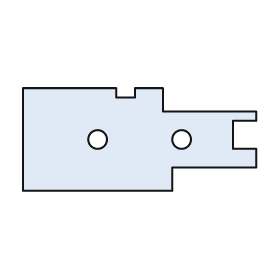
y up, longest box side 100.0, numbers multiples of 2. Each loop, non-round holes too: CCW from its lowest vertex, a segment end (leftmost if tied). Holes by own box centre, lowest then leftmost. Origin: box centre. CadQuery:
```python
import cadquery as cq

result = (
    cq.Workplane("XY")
    .moveTo(-50.0, -22.0)
    .lineTo(14.0, -22.0)
    .lineTo(14.0, -12.0)
    .lineTo(50.0, -12.0)
    .lineTo(50.0, -4.0)
    .lineTo(40.0, -4.0)
    .lineTo(40.0, 8.0)
    .lineTo(50.0, 8.0)
    .lineTo(50.0, 12.0)
    .lineTo(10.0, 12.0)
    .lineTo(10.0, 22.0)
    .lineTo(-2.0, 22.0)
    .lineTo(-2.0, 18.0)
    .lineTo(-10.0, 18.0)
    .lineTo(-10.0, 22.0)
    .lineTo(-50.0, 22.0)
    .close()
    .moveTo(-18.0, 0.0)
    .circle(4.0)
    .moveTo(18.0, 0.0)
    .circle(4.0)
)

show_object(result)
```